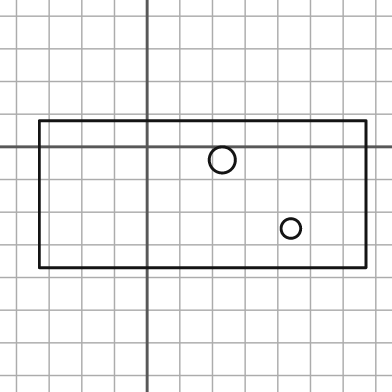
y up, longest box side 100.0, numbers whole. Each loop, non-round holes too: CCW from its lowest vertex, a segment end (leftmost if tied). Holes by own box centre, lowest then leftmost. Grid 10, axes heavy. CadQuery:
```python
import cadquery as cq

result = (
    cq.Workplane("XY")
    .moveTo(-33.0, -37.0)
    .lineTo(67.0, -37.0)
    .lineTo(67.0, 8.0)
    .lineTo(-33.0, 8.0)
    .close()
    .moveTo(44.0, -25.0)
    .circle(3.0)
    .moveTo(23.0, -4.0)
    .circle(4.0)
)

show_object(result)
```